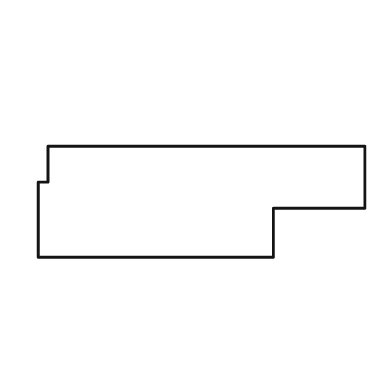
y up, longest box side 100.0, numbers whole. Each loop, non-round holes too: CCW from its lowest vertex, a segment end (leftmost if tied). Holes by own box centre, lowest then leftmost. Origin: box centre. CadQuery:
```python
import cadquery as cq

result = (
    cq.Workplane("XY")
    .moveTo(-50.0, -17.0)
    .lineTo(22.0, -17.0)
    .lineTo(22.0, -2.0)
    .lineTo(50.0, -2.0)
    .lineTo(50.0, 17.0)
    .lineTo(-47.0, 17.0)
    .lineTo(-47.0, 6.0)
    .lineTo(-50.0, 6.0)
    .close()
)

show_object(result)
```